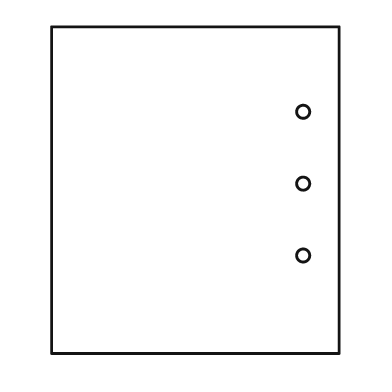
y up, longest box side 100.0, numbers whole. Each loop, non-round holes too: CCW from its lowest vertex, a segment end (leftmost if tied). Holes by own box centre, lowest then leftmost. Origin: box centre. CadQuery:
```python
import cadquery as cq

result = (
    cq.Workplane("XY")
    .moveTo(-44.0, -50.0)
    .lineTo(44.0, -50.0)
    .lineTo(44.0, 50.0)
    .lineTo(-44.0, 50.0)
    .close()
    .moveTo(33.0, -20.0)
    .circle(2.0)
    .moveTo(33.0, 2.0)
    .circle(2.0)
    .moveTo(33.0, 24.0)
    .circle(2.0)
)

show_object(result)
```